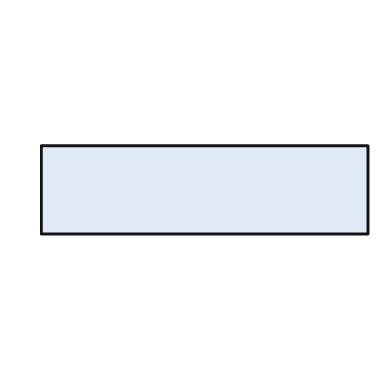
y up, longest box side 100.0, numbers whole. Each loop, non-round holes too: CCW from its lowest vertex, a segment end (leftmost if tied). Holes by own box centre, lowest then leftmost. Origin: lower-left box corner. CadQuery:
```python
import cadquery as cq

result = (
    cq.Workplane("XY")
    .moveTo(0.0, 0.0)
    .lineTo(100.0, 0.0)
    .lineTo(100.0, 27.0)
    .lineTo(0.0, 27.0)
    .close()
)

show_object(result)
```